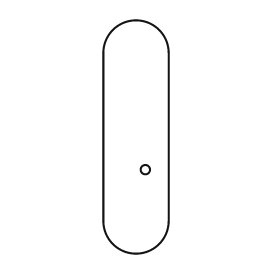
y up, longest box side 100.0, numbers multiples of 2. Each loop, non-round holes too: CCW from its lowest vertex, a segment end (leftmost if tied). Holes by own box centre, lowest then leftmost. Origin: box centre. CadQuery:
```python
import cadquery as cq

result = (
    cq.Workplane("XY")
    .moveTo(-14.0, -36.0)
    .threePointArc((0.0, -50.0), (14.0, -36.0))
    .lineTo(14.0, 36.0)
    .threePointArc((0.0, 50.0), (-14.0, 36.0))
    .close()
    .moveTo(4.0, -14.0)
    .circle(2.0)
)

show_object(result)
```